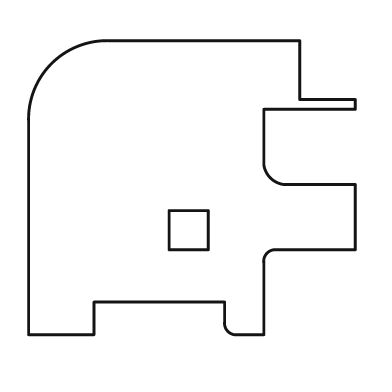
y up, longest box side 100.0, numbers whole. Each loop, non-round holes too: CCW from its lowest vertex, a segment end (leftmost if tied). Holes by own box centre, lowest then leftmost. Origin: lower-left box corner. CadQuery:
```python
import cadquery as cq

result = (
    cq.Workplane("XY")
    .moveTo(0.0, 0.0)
    .lineTo(20.0, 0.0)
    .lineTo(20.0, 10.0)
    .lineTo(60.0, 10.0)
    .lineTo(60.0, 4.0)
    .threePointArc((61.0, 1.0), (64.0, 0.0))
    .lineTo(72.0, 0.0)
    .lineTo(72.0, 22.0)
    .threePointArc((73.0, 25.0), (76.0, 26.0))
    .lineTo(100.0, 26.0)
    .lineTo(100.0, 46.0)
    .lineTo(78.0, 46.0)
    .threePointArc((74.0, 48.0), (72.0, 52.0))
    .lineTo(72.0, 69.0)
    .lineTo(100.0, 69.0)
    .lineTo(100.0, 72.0)
    .lineTo(83.0, 72.0)
    .lineTo(83.0, 90.0)
    .lineTo(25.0, 90.0)
    .threePointArc((7.0, 83.0), (0.0, 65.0))
    .close()
    .moveTo(43.0, 26.0)
    .lineTo(55.0, 26.0)
    .lineTo(55.0, 38.0)
    .lineTo(43.0, 38.0)
    .close()
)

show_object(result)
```